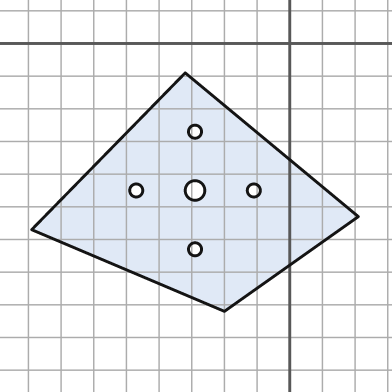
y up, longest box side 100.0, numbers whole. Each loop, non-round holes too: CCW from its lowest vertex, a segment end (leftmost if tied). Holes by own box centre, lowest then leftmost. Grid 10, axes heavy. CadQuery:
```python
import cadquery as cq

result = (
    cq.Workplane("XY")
    .moveTo(-20.0, -82.0)
    .lineTo(21.0, -53.0)
    .lineTo(-32.0, -9.0)
    .lineTo(-79.0, -57.0)
    .close()
    .moveTo(-29.0, -63.0)
    .circle(2.0)
    .moveTo(-47.0, -45.0)
    .circle(2.0)
    .moveTo(-29.0, -45.0)
    .circle(3.0)
    .moveTo(-11.0, -45.0)
    .circle(2.0)
    .moveTo(-29.0, -27.0)
    .circle(2.0)
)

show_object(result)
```